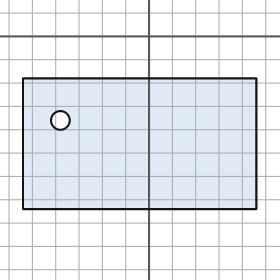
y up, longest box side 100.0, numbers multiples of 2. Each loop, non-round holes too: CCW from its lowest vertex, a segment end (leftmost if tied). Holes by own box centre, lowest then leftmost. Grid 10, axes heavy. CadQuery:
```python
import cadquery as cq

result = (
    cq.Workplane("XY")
    .moveTo(-54.0, -74.0)
    .lineTo(46.0, -74.0)
    .lineTo(46.0, -18.0)
    .lineTo(-54.0, -18.0)
    .close()
    .moveTo(-38.0, -36.0)
    .circle(4.0)
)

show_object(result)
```